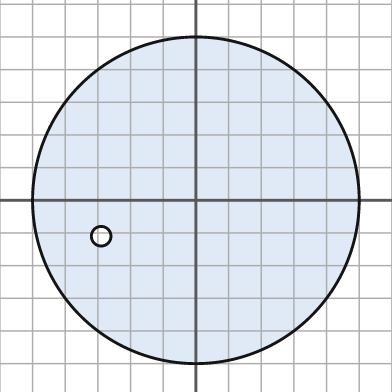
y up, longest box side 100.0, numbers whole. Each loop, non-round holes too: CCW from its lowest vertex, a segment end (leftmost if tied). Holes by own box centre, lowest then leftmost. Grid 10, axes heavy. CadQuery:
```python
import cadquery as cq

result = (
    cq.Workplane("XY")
    .moveTo(0.0, 0.0)
    .circle(50.0)
    .moveTo(-29.0, -11.0)
    .circle(3.0)
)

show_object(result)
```